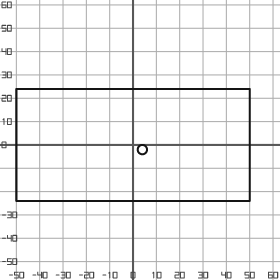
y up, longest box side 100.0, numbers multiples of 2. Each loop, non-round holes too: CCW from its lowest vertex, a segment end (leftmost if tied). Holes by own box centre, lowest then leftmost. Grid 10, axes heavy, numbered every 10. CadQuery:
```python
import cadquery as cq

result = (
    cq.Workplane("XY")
    .moveTo(-50.0, -24.0)
    .lineTo(50.0, -24.0)
    .lineTo(50.0, 24.0)
    .lineTo(-50.0, 24.0)
    .close()
    .moveTo(4.0, -2.0)
    .circle(2.0)
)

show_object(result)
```